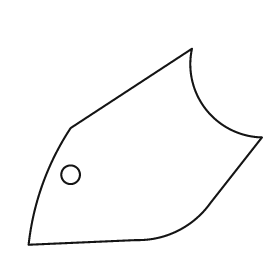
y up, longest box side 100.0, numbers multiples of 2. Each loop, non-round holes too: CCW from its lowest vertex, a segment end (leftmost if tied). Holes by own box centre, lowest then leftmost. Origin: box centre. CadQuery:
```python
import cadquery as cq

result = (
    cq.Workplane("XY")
    .moveTo(-50.0, -42.0)
    .lineTo(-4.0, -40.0)
    .threePointArc((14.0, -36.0), (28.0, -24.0))
    .lineTo(50.0, 4.0)
    .threePointArc((26.0, 16.0), (20.0, 42.0))
    .lineTo(-32.0, 8.0)
    .threePointArc((-44.0, -16.0), (-50.0, -42.0))
    .close()
    .moveTo(-32.0, -12.0)
    .circle(4.0)
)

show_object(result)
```